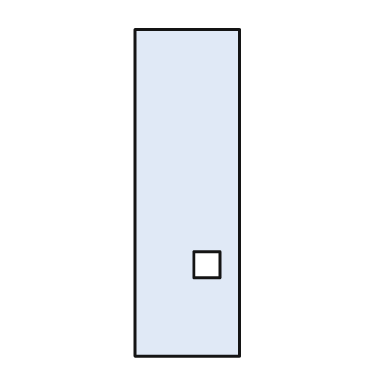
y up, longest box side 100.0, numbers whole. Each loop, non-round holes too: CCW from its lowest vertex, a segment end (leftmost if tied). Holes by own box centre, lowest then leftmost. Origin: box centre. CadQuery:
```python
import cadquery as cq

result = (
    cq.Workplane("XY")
    .moveTo(-16.0, -50.0)
    .lineTo(16.0, -50.0)
    .lineTo(16.0, 50.0)
    .lineTo(-16.0, 50.0)
    .close()
    .moveTo(2.0, -26.0)
    .lineTo(10.0, -26.0)
    .lineTo(10.0, -18.0)
    .lineTo(2.0, -18.0)
    .close()
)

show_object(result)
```